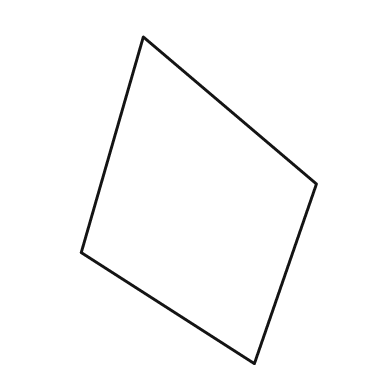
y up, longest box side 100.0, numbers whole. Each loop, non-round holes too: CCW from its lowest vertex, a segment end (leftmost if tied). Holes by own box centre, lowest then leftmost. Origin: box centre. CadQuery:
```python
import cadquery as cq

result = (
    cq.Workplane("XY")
    .moveTo(17.0, -50.0)
    .lineTo(36.0, 5.0)
    .lineTo(-17.0, 50.0)
    .lineTo(-36.0, -16.0)
    .close()
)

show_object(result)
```